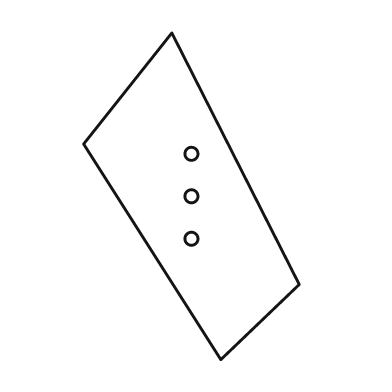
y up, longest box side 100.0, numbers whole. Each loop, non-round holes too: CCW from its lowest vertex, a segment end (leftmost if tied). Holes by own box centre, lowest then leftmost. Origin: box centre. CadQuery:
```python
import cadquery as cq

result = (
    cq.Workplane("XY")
    .moveTo(9.0, -50.0)
    .lineTo(33.0, -27.0)
    .lineTo(-6.0, 50.0)
    .lineTo(-33.0, 16.0)
    .close()
    .moveTo(0.0, -13.0)
    .circle(2.0)
    .moveTo(0.0, 0.0)
    .circle(2.0)
    .moveTo(0.0, 13.0)
    .circle(2.0)
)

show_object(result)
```